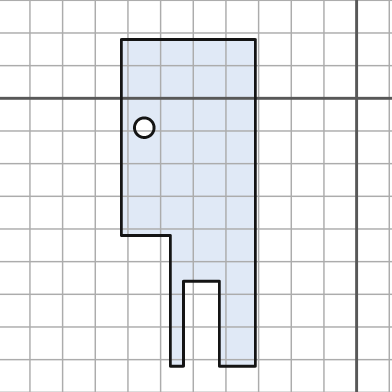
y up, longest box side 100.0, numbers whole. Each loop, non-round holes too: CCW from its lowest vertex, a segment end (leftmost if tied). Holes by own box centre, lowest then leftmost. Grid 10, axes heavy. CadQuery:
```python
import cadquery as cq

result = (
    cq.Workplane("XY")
    .moveTo(-57.0, -82.0)
    .lineTo(-53.0, -82.0)
    .lineTo(-53.0, -56.0)
    .lineTo(-42.0, -56.0)
    .lineTo(-42.0, -82.0)
    .lineTo(-31.0, -82.0)
    .lineTo(-31.0, 18.0)
    .lineTo(-72.0, 18.0)
    .lineTo(-72.0, -42.0)
    .lineTo(-57.0, -42.0)
    .close()
    .moveTo(-65.0, -9.0)
    .circle(3.0)
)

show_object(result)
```